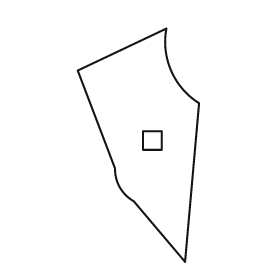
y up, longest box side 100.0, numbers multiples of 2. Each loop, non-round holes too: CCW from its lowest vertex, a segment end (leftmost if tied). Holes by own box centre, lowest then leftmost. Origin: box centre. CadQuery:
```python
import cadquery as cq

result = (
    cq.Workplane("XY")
    .moveTo(20.0, -50.0)
    .lineTo(26.0, 18.0)
    .threePointArc((14.0, 32.0), (12.0, 50.0))
    .lineTo(-26.0, 32.0)
    .lineTo(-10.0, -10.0)
    .threePointArc((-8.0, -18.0), (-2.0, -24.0))
    .close()
    .moveTo(2.0, -2.0)
    .lineTo(10.0, -2.0)
    .lineTo(10.0, 6.0)
    .lineTo(2.0, 6.0)
    .close()
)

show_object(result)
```